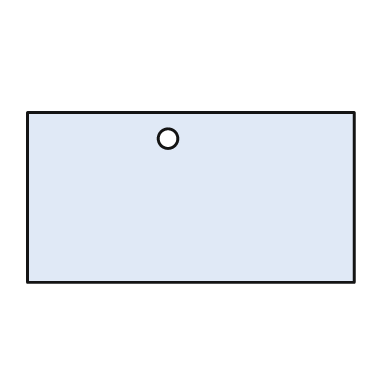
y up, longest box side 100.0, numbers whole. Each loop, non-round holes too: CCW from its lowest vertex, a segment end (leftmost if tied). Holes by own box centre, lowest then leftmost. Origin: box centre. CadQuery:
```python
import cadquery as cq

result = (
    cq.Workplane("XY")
    .moveTo(-50.0, -26.0)
    .lineTo(50.0, -26.0)
    .lineTo(50.0, 26.0)
    .lineTo(-50.0, 26.0)
    .close()
    .moveTo(-7.0, 18.0)
    .circle(3.0)
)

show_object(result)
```